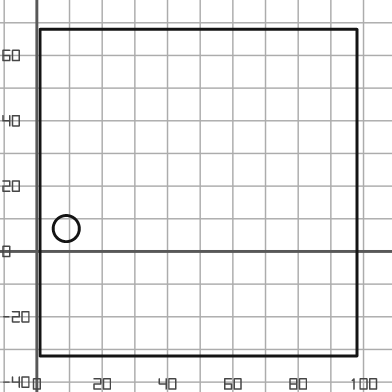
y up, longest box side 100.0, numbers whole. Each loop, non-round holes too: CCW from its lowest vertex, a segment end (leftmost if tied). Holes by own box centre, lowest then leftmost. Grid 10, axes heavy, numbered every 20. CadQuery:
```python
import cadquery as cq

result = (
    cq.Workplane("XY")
    .moveTo(1.0, -32.0)
    .lineTo(98.0, -32.0)
    .lineTo(98.0, 68.0)
    .lineTo(1.0, 68.0)
    .close()
    .moveTo(9.0, 7.0)
    .circle(4.0)
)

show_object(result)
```